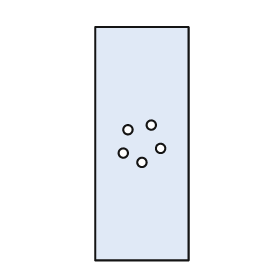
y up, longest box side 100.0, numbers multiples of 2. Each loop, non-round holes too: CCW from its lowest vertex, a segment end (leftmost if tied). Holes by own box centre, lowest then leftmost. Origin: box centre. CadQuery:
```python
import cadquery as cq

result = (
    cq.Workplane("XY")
    .moveTo(-20.0, -50.0)
    .lineTo(20.0, -50.0)
    .lineTo(20.0, 50.0)
    .lineTo(-20.0, 50.0)
    .close()
    .moveTo(0.0, -8.0)
    .circle(2.0)
    .moveTo(-8.0, -4.0)
    .circle(2.0)
    .moveTo(8.0, -2.0)
    .circle(2.0)
    .moveTo(-6.0, 6.0)
    .circle(2.0)
    .moveTo(4.0, 8.0)
    .circle(2.0)
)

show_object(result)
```